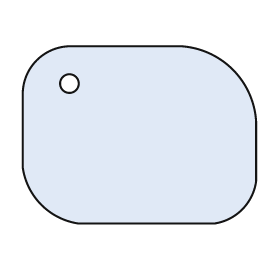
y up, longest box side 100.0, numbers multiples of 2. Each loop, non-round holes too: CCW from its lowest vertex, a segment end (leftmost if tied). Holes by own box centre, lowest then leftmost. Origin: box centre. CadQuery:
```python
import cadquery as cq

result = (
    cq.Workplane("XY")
    .moveTo(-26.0, -38.0)
    .lineTo(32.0, -38.0)
    .threePointArc((44.0, -32.0), (50.0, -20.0))
    .lineTo(50.0, 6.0)
    .threePointArc((40.0, 28.0), (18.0, 38.0))
    .lineTo(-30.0, 38.0)
    .threePointArc((-44.0, 32.0), (-50.0, 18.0))
    .lineTo(-50.0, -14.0)
    .threePointArc((-42.0, -30.0), (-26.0, -38.0))
    .close()
    .moveTo(-30.0, 22.0)
    .circle(4.0)
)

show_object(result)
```